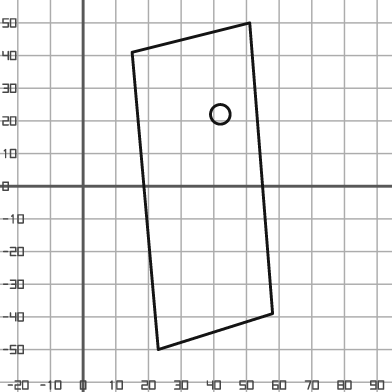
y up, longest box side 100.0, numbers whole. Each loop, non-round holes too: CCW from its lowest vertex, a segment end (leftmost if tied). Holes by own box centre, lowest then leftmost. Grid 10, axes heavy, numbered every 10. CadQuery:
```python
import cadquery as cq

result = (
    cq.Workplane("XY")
    .moveTo(23.0, -50.0)
    .lineTo(58.0, -39.0)
    .lineTo(51.0, 50.0)
    .lineTo(15.0, 41.0)
    .close()
    .moveTo(42.0, 22.0)
    .circle(3.0)
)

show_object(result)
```